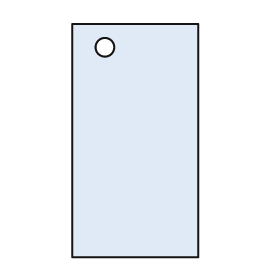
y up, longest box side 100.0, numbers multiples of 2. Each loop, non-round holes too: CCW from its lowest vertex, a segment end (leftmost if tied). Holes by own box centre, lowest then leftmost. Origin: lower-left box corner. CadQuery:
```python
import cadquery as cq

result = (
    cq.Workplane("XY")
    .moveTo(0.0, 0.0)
    .lineTo(54.0, 0.0)
    .lineTo(54.0, 100.0)
    .lineTo(0.0, 100.0)
    .close()
    .moveTo(14.0, 90.0)
    .circle(4.0)
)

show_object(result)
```